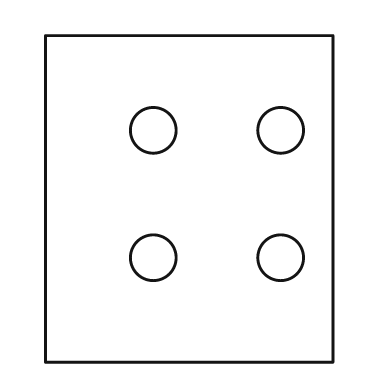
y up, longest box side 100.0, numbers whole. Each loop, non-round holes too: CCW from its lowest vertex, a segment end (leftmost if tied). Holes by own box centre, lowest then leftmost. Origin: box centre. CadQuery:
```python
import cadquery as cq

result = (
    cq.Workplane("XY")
    .moveTo(-44.0, -50.0)
    .lineTo(44.0, -50.0)
    .lineTo(44.0, 50.0)
    .lineTo(-44.0, 50.0)
    .close()
    .moveTo(-11.0, -18.0)
    .circle(7.0)
    .moveTo(28.0, -18.0)
    .circle(7.0)
    .moveTo(-11.0, 21.0)
    .circle(7.0)
    .moveTo(28.0, 21.0)
    .circle(7.0)
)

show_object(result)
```